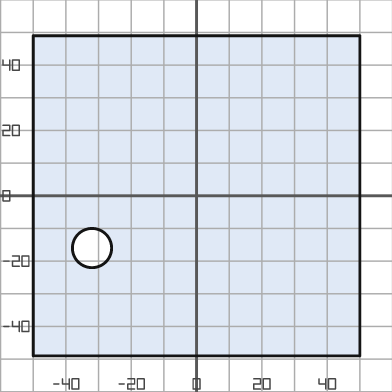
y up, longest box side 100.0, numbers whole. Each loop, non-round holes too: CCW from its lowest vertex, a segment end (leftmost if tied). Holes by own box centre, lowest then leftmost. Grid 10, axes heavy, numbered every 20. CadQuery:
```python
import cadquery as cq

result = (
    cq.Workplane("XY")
    .moveTo(-50.0, -49.0)
    .lineTo(50.0, -49.0)
    .lineTo(50.0, 49.0)
    .lineTo(-50.0, 49.0)
    .close()
    .moveTo(-32.0, -16.0)
    .circle(6.0)
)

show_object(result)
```